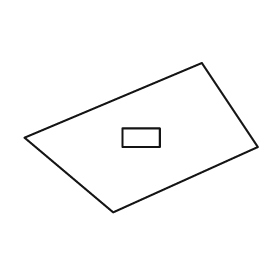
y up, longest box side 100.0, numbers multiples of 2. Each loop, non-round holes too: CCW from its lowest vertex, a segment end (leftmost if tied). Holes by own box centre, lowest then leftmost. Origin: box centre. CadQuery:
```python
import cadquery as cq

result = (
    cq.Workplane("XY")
    .moveTo(-12.0, -32.0)
    .lineTo(50.0, -4.0)
    .lineTo(26.0, 32.0)
    .lineTo(-50.0, 0.0)
    .close()
    .moveTo(-8.0, -4.0)
    .lineTo(8.0, -4.0)
    .lineTo(8.0, 4.0)
    .lineTo(-8.0, 4.0)
    .close()
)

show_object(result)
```